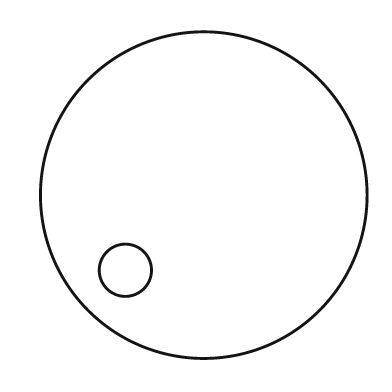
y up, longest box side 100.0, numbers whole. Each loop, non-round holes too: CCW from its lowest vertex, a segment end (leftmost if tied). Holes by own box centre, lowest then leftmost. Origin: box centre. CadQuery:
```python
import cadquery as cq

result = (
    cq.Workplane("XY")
    .moveTo(0.0, 0.0)
    .circle(50.0)
    .moveTo(-24.0, -23.0)
    .circle(8.0)
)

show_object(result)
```